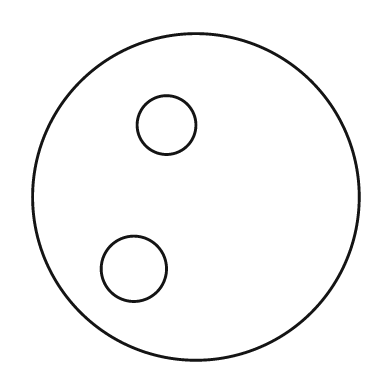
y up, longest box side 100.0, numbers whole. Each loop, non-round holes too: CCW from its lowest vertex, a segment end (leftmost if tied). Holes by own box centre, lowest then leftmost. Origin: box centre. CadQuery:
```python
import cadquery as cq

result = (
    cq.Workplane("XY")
    .moveTo(0.0, 0.0)
    .circle(50.0)
    .moveTo(-19.0, -22.0)
    .circle(10.0)
    .moveTo(-9.0, 22.0)
    .circle(9.0)
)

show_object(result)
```